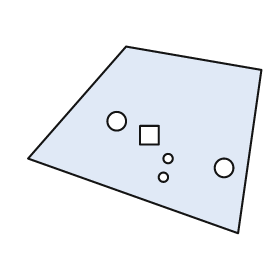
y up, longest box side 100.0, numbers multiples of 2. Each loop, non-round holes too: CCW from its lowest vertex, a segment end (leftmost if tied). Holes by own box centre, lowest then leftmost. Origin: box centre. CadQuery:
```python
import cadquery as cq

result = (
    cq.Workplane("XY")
    .moveTo(40.0, -40.0)
    .lineTo(50.0, 30.0)
    .lineTo(-8.0, 40.0)
    .lineTo(-50.0, -8.0)
    .close()
    .moveTo(8.0, -16.0)
    .circle(2.0)
    .moveTo(34.0, -12.0)
    .circle(4.0)
    .moveTo(10.0, -8.0)
    .circle(2.0)
    .moveTo(-2.0, -2.0)
    .lineTo(6.0, -2.0)
    .lineTo(6.0, 6.0)
    .lineTo(-2.0, 6.0)
    .close()
    .moveTo(-12.0, 8.0)
    .circle(4.0)
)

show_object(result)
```